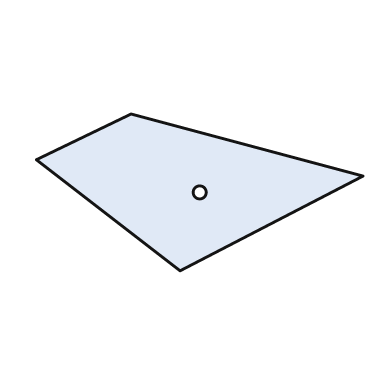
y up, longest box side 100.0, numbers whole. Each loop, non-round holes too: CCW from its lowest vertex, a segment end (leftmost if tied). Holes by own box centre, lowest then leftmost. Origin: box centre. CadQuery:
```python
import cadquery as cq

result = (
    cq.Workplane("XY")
    .moveTo(-6.0, -24.0)
    .lineTo(50.0, 5.0)
    .lineTo(-21.0, 24.0)
    .lineTo(-50.0, 10.0)
    .close()
    .moveTo(0.0, 0.0)
    .circle(2.0)
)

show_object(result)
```